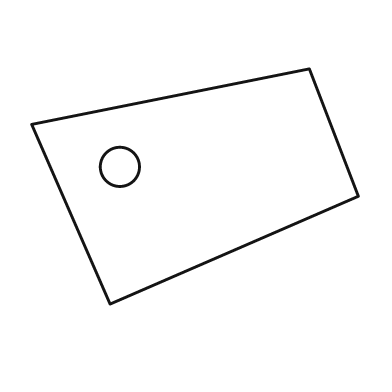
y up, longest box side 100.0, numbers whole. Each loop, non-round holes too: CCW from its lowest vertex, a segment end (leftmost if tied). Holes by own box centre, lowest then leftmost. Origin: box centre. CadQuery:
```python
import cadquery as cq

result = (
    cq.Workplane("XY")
    .moveTo(-26.0, -36.0)
    .lineTo(50.0, -3.0)
    .lineTo(35.0, 36.0)
    .lineTo(-50.0, 19.0)
    .close()
    .moveTo(-23.0, 6.0)
    .circle(6.0)
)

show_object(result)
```